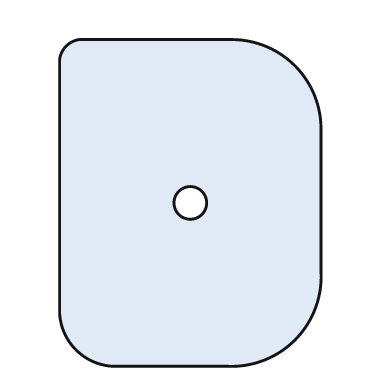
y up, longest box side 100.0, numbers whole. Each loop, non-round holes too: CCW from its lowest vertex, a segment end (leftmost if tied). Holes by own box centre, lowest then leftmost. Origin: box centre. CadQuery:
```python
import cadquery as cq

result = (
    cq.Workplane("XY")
    .moveTo(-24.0, -50.0)
    .lineTo(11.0, -50.0)
    .threePointArc((32.0, -42.0), (40.0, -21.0))
    .lineTo(40.0, 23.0)
    .threePointArc((32.0, 42.0), (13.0, 50.0))
    .lineTo(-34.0, 50.0)
    .threePointArc((-38.0, 48.0), (-40.0, 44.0))
    .lineTo(-40.0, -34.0)
    .threePointArc((-35.0, -45.0), (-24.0, -50.0))
    .close()
    .moveTo(0.0, 0.0)
    .circle(5.0)
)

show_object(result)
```